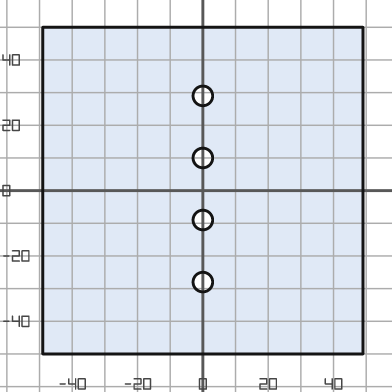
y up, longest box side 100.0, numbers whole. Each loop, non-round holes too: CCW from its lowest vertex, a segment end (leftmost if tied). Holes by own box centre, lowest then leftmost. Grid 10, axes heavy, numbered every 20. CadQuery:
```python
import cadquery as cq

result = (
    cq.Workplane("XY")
    .moveTo(-49.0, -50.0)
    .lineTo(49.0, -50.0)
    .lineTo(49.0, 50.0)
    .lineTo(-49.0, 50.0)
    .close()
    .moveTo(0.0, -28.0)
    .circle(3.0)
    .moveTo(0.0, -9.0)
    .circle(3.0)
    .moveTo(0.0, 10.0)
    .circle(3.0)
    .moveTo(0.0, 29.0)
    .circle(3.0)
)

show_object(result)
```